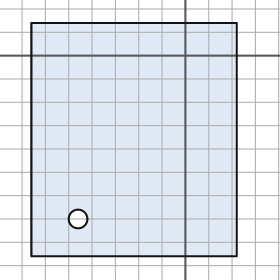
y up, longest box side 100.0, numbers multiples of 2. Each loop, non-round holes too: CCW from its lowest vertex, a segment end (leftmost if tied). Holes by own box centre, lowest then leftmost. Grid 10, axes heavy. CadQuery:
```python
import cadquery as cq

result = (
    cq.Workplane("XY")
    .moveTo(-66.0, -86.0)
    .lineTo(22.0, -86.0)
    .lineTo(22.0, 14.0)
    .lineTo(-66.0, 14.0)
    .close()
    .moveTo(-46.0, -70.0)
    .circle(4.0)
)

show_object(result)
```